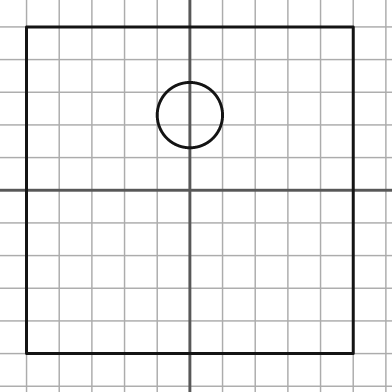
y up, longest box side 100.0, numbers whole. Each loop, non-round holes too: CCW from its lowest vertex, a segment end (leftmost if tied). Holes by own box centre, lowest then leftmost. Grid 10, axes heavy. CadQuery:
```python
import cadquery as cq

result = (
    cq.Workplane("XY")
    .moveTo(-50.0, -50.0)
    .lineTo(50.0, -50.0)
    .lineTo(50.0, 50.0)
    .lineTo(-50.0, 50.0)
    .close()
    .moveTo(0.0, 23.0)
    .circle(10.0)
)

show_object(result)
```